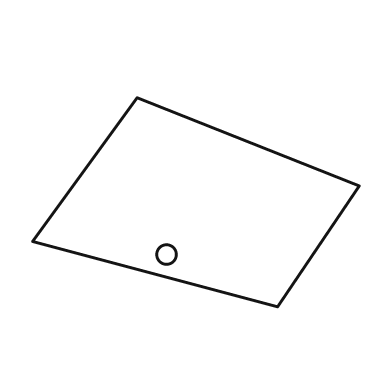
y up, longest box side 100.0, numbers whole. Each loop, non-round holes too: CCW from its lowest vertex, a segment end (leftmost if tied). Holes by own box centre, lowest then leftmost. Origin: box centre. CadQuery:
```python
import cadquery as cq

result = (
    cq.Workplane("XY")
    .moveTo(25.0, -32.0)
    .lineTo(50.0, 5.0)
    .lineTo(-18.0, 32.0)
    .lineTo(-50.0, -12.0)
    .close()
    .moveTo(-9.0, -16.0)
    .circle(3.0)
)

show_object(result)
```